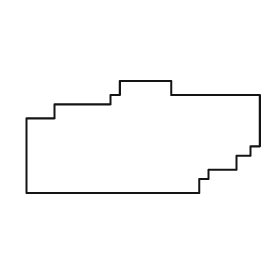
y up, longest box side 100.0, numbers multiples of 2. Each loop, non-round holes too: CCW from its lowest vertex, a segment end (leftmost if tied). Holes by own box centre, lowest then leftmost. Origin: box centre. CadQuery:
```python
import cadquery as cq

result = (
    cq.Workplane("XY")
    .moveTo(-50.0, -24.0)
    .lineTo(24.0, -24.0)
    .lineTo(24.0, -18.0)
    .lineTo(28.0, -18.0)
    .lineTo(28.0, -14.0)
    .lineTo(40.0, -14.0)
    .lineTo(40.0, -8.0)
    .lineTo(46.0, -8.0)
    .lineTo(46.0, -4.0)
    .lineTo(50.0, -4.0)
    .lineTo(50.0, 18.0)
    .lineTo(12.0, 18.0)
    .lineTo(12.0, 24.0)
    .lineTo(-10.0, 24.0)
    .lineTo(-10.0, 18.0)
    .lineTo(-14.0, 18.0)
    .lineTo(-14.0, 14.0)
    .lineTo(-38.0, 14.0)
    .lineTo(-38.0, 8.0)
    .lineTo(-50.0, 8.0)
    .close()
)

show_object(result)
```